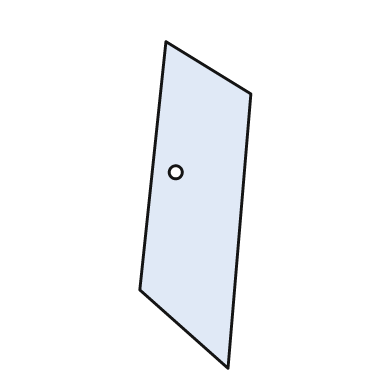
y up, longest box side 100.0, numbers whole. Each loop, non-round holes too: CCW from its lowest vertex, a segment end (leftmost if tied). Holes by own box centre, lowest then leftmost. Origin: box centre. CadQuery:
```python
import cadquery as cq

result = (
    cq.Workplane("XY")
    .moveTo(10.0, -50.0)
    .lineTo(17.0, 34.0)
    .lineTo(-9.0, 50.0)
    .lineTo(-17.0, -26.0)
    .close()
    .moveTo(-6.0, 10.0)
    .circle(2.0)
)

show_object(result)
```